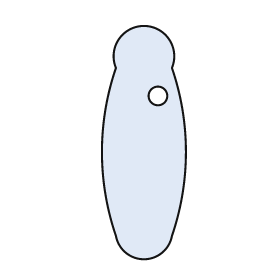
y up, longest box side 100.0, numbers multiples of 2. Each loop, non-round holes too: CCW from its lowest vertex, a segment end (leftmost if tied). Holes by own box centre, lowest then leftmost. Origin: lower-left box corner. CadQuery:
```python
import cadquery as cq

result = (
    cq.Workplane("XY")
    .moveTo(6.0, 10.0)
    .threePointArc((18.0, 0.0), (30.0, 10.0))
    .threePointArc((36.0, 46.0), (30.0, 82.0))
    .threePointArc((18.0, 100.0), (6.0, 82.0))
    .threePointArc((0.0, 46.0), (6.0, 10.0))
    .close()
    .moveTo(24.0, 70.0)
    .circle(4.0)
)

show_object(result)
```